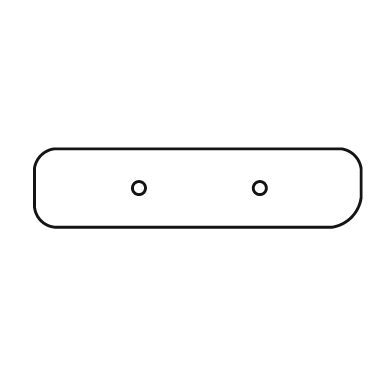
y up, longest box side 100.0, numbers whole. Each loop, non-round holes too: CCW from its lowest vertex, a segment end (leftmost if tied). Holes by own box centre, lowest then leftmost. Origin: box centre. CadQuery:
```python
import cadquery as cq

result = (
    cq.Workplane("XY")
    .moveTo(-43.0, -12.0)
    .lineTo(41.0, -12.0)
    .threePointArc((47.0, -9.0), (50.0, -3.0))
    .lineTo(50.0, 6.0)
    .threePointArc((48.0, 10.0), (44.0, 12.0))
    .lineTo(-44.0, 12.0)
    .threePointArc((-48.0, 10.0), (-50.0, 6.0))
    .lineTo(-50.0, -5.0)
    .threePointArc((-48.0, -10.0), (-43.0, -12.0))
    .close()
    .moveTo(-18.0, 0.0)
    .circle(2.0)
    .moveTo(19.0, 0.0)
    .circle(2.0)
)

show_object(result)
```